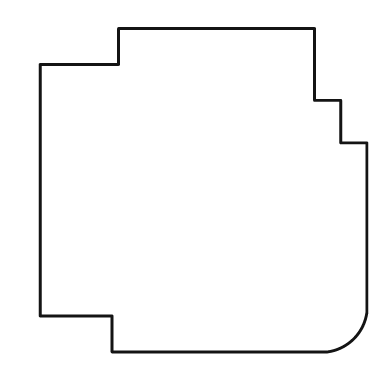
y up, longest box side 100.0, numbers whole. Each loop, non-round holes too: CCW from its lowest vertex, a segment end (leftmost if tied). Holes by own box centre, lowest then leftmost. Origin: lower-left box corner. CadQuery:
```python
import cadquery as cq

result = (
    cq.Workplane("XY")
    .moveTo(22.0, 0.0)
    .lineTo(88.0, 0.0)
    .threePointArc((96.0, 4.0), (100.0, 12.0))
    .lineTo(100.0, 64.0)
    .lineTo(92.0, 64.0)
    .lineTo(92.0, 77.0)
    .lineTo(84.0, 77.0)
    .lineTo(84.0, 99.0)
    .lineTo(24.0, 99.0)
    .lineTo(24.0, 88.0)
    .lineTo(0.0, 88.0)
    .lineTo(0.0, 11.0)
    .lineTo(22.0, 11.0)
    .close()
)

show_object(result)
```